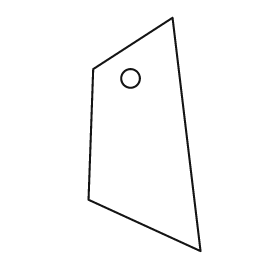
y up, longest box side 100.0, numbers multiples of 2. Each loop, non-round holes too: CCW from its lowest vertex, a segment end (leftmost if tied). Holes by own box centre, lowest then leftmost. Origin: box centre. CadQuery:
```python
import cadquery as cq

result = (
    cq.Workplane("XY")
    .moveTo(24.0, -50.0)
    .lineTo(12.0, 50.0)
    .lineTo(-22.0, 28.0)
    .lineTo(-24.0, -28.0)
    .close()
    .moveTo(-6.0, 24.0)
    .circle(4.0)
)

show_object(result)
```